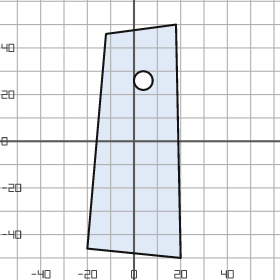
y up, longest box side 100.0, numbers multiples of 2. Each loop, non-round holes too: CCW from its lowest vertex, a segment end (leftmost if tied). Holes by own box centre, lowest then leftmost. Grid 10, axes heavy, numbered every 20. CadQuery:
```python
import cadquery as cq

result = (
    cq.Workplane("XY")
    .moveTo(20.0, -50.0)
    .lineTo(18.0, 50.0)
    .lineTo(-12.0, 46.0)
    .lineTo(-20.0, -46.0)
    .close()
    .moveTo(4.0, 26.0)
    .circle(4.0)
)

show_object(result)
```